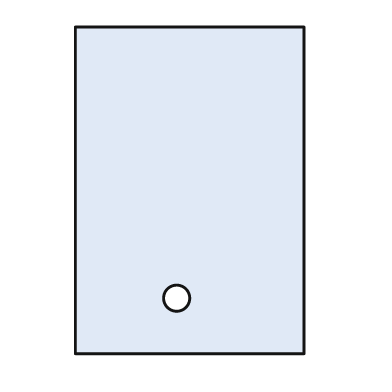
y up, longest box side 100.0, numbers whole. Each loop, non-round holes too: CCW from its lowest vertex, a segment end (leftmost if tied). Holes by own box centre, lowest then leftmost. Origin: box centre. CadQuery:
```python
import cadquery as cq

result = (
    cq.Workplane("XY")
    .moveTo(-35.0, -50.0)
    .lineTo(35.0, -50.0)
    .lineTo(35.0, 50.0)
    .lineTo(-35.0, 50.0)
    .close()
    .moveTo(-4.0, -33.0)
    .circle(4.0)
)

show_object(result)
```